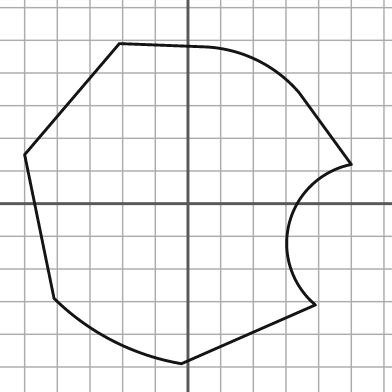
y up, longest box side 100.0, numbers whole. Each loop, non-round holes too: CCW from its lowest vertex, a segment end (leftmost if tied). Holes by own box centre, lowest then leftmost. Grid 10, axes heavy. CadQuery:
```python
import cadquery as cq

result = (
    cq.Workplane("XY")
    .moveTo(-2.0, -49.0)
    .lineTo(39.0, -31.0)
    .threePointArc((31.0, -6.0), (50.0, 12.0))
    .lineTo(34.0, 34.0)
    .threePointArc((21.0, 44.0), (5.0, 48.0))
    .lineTo(-21.0, 49.0)
    .lineTo(-50.0, 15.0)
    .lineTo(-41.0, -29.0)
    .threePointArc((-23.0, -42.0), (-2.0, -49.0))
    .close()
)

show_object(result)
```